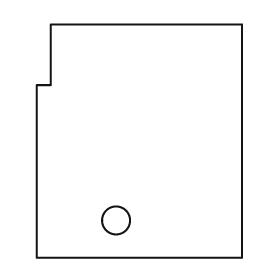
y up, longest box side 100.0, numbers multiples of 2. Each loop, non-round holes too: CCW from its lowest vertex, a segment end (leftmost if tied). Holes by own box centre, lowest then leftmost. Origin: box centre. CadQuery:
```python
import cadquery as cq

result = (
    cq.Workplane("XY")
    .moveTo(-44.0, -50.0)
    .lineTo(44.0, -50.0)
    .lineTo(44.0, 50.0)
    .lineTo(-38.0, 50.0)
    .lineTo(-38.0, 24.0)
    .lineTo(-44.0, 24.0)
    .close()
    .moveTo(-10.0, -34.0)
    .circle(6.0)
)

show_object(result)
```